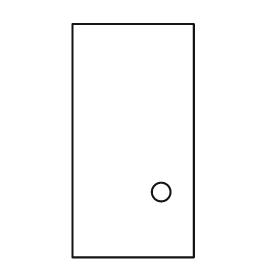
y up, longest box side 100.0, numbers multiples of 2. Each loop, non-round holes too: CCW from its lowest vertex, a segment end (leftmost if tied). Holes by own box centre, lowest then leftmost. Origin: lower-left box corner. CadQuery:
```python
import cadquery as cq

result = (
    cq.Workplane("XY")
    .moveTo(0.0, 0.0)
    .lineTo(52.0, 0.0)
    .lineTo(52.0, 100.0)
    .lineTo(0.0, 100.0)
    .close()
    .moveTo(38.0, 28.0)
    .circle(4.0)
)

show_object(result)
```